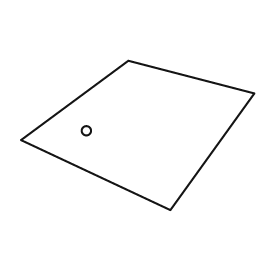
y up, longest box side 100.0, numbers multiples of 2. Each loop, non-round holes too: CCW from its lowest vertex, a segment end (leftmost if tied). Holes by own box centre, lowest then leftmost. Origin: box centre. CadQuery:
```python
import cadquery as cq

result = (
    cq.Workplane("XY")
    .moveTo(14.0, -32.0)
    .lineTo(50.0, 18.0)
    .lineTo(-4.0, 32.0)
    .lineTo(-50.0, -2.0)
    .close()
    .moveTo(-22.0, 2.0)
    .circle(2.0)
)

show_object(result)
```